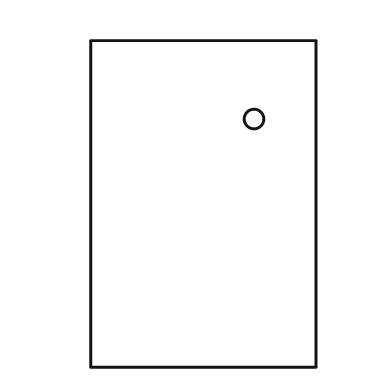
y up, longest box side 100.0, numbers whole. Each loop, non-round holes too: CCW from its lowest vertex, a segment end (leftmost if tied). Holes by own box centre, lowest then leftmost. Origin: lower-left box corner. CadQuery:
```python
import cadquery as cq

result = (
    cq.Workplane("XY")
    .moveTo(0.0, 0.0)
    .lineTo(69.0, 0.0)
    .lineTo(69.0, 100.0)
    .lineTo(0.0, 100.0)
    .close()
    .moveTo(50.0, 76.0)
    .circle(3.0)
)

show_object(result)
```